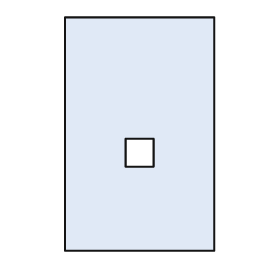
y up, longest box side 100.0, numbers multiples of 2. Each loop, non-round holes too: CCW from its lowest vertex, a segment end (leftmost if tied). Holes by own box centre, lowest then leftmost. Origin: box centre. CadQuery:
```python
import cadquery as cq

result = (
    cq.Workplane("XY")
    .moveTo(-32.0, -50.0)
    .lineTo(32.0, -50.0)
    .lineTo(32.0, 50.0)
    .lineTo(-32.0, 50.0)
    .close()
    .moveTo(-6.0, -14.0)
    .lineTo(6.0, -14.0)
    .lineTo(6.0, -2.0)
    .lineTo(-6.0, -2.0)
    .close()
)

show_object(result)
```